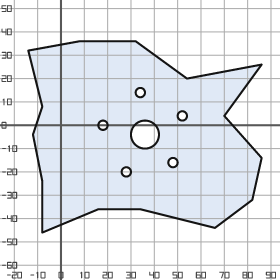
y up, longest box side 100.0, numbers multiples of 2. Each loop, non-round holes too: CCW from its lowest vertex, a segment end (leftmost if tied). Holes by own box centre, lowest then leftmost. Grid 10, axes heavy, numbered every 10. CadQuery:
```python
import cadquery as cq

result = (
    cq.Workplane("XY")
    .moveTo(-8.0, -46.0)
    .lineTo(16.0, -36.0)
    .lineTo(34.0, -36.0)
    .lineTo(66.0, -44.0)
    .lineTo(82.0, -32.0)
    .lineTo(86.0, -14.0)
    .lineTo(70.0, 4.0)
    .lineTo(86.0, 26.0)
    .lineTo(54.0, 20.0)
    .lineTo(32.0, 36.0)
    .lineTo(8.0, 36.0)
    .lineTo(-14.0, 32.0)
    .lineTo(-8.0, 8.0)
    .lineTo(-12.0, -4.0)
    .lineTo(-8.0, -24.0)
    .close()
    .moveTo(28.0, -20.0)
    .circle(2.0)
    .moveTo(48.0, -16.0)
    .circle(2.0)
    .moveTo(36.0, -4.0)
    .circle(6.0)
    .moveTo(18.0, 0.0)
    .circle(2.0)
    .moveTo(52.0, 4.0)
    .circle(2.0)
    .moveTo(34.0, 14.0)
    .circle(2.0)
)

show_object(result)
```